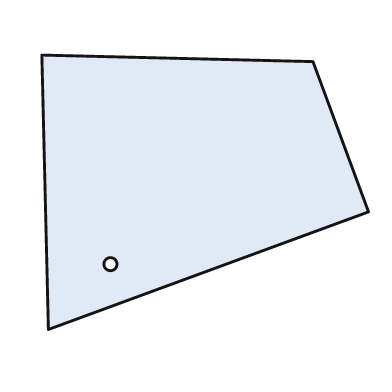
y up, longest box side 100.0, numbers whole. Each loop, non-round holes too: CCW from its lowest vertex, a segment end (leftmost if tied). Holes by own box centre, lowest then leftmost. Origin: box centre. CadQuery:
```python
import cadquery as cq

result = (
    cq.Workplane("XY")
    .moveTo(-48.0, -42.0)
    .lineTo(50.0, -6.0)
    .lineTo(33.0, 40.0)
    .lineTo(-50.0, 42.0)
    .close()
    .moveTo(-29.0, -22.0)
    .circle(2.0)
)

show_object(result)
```